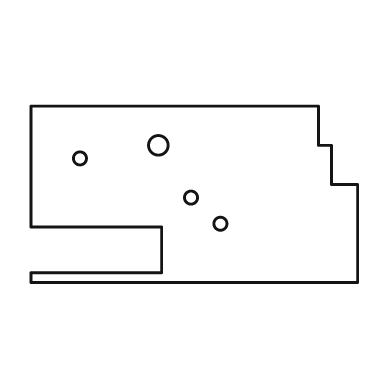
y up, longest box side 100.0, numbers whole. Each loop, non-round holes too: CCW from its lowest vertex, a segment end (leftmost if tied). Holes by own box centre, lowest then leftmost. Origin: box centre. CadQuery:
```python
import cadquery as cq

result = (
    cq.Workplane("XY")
    .moveTo(-50.0, -27.0)
    .lineTo(50.0, -27.0)
    .lineTo(50.0, 3.0)
    .lineTo(42.0, 3.0)
    .lineTo(42.0, 15.0)
    .lineTo(38.0, 15.0)
    .lineTo(38.0, 27.0)
    .lineTo(-50.0, 27.0)
    .lineTo(-50.0, -10.0)
    .lineTo(-10.0, -10.0)
    .lineTo(-10.0, -24.0)
    .lineTo(-50.0, -24.0)
    .close()
    .moveTo(8.0, -9.0)
    .circle(2.0)
    .moveTo(-1.0, -1.0)
    .circle(2.0)
    .moveTo(-35.0, 11.0)
    .circle(2.0)
    .moveTo(-11.0, 15.0)
    .circle(3.0)
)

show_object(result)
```